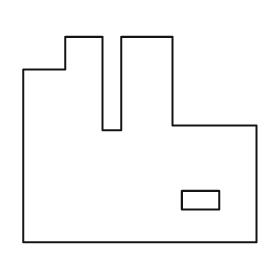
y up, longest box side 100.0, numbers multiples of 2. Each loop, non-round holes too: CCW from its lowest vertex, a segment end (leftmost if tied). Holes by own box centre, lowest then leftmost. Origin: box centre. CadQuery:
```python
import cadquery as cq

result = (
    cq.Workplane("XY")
    .moveTo(-50.0, -44.0)
    .lineTo(50.0, -44.0)
    .lineTo(50.0, 6.0)
    .lineTo(14.0, 6.0)
    .lineTo(14.0, 44.0)
    .lineTo(-8.0, 44.0)
    .lineTo(-8.0, 4.0)
    .lineTo(-16.0, 4.0)
    .lineTo(-16.0, 44.0)
    .lineTo(-32.0, 44.0)
    .lineTo(-32.0, 30.0)
    .lineTo(-50.0, 30.0)
    .close()
    .moveTo(18.0, -30.0)
    .lineTo(34.0, -30.0)
    .lineTo(34.0, -22.0)
    .lineTo(18.0, -22.0)
    .close()
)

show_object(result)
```